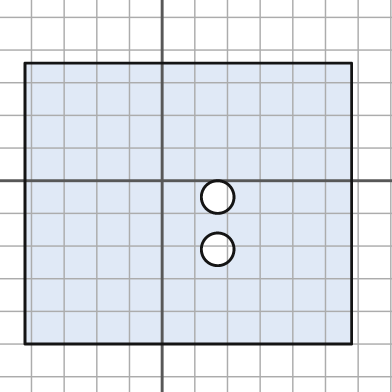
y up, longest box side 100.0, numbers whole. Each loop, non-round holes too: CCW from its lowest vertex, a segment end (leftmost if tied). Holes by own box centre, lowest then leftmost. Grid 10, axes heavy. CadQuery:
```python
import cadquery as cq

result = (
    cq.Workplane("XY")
    .moveTo(-42.0, -50.0)
    .lineTo(58.0, -50.0)
    .lineTo(58.0, 36.0)
    .lineTo(-42.0, 36.0)
    .close()
    .moveTo(17.0, -21.0)
    .circle(5.0)
    .moveTo(17.0, -5.0)
    .circle(5.0)
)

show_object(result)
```